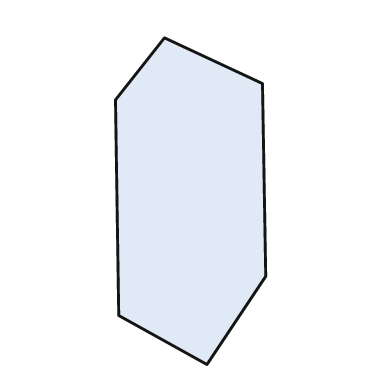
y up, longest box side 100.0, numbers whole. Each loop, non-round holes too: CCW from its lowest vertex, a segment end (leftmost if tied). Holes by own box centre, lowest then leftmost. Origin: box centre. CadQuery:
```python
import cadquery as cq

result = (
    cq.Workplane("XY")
    .moveTo(5.0, -50.0)
    .lineTo(23.0, -23.0)
    .lineTo(22.0, 36.0)
    .lineTo(-8.0, 50.0)
    .lineTo(-23.0, 31.0)
    .lineTo(-22.0, -35.0)
    .close()
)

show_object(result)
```